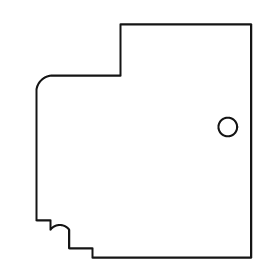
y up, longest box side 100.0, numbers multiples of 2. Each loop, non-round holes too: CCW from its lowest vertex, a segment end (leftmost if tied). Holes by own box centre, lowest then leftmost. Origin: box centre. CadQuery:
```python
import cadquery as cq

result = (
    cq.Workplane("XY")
    .moveTo(-22.0, -50.0)
    .lineTo(46.0, -50.0)
    .lineTo(46.0, 50.0)
    .lineTo(-10.0, 50.0)
    .lineTo(-10.0, 28.0)
    .lineTo(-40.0, 28.0)
    .threePointArc((-44.0, 26.0), (-46.0, 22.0))
    .lineTo(-46.0, -34.0)
    .lineTo(-40.0, -34.0)
    .lineTo(-40.0, -38.0)
    .threePointArc((-36.0, -36.0), (-32.0, -38.0))
    .lineTo(-32.0, -46.0)
    .lineTo(-22.0, -46.0)
    .close()
    .moveTo(36.0, 6.0)
    .circle(4.0)
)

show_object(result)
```